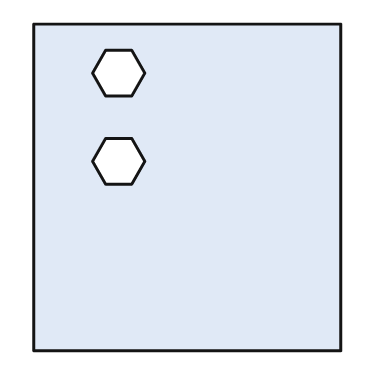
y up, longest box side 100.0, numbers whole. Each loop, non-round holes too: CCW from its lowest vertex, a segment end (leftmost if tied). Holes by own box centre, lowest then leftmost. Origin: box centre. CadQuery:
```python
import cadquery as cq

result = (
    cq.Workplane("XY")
    .moveTo(-47.0, -50.0)
    .lineTo(47.0, -50.0)
    .lineTo(47.0, 50.0)
    .lineTo(-47.0, 50.0)
    .close()
    .moveTo(-25.0, 1.0)
    .lineTo(-17.0, 1.0)
    .lineTo(-13.0, 8.0)
    .lineTo(-17.0, 15.0)
    .lineTo(-25.0, 15.0)
    .lineTo(-29.0, 8.0)
    .close()
    .moveTo(-25.0, 28.0)
    .lineTo(-17.0, 28.0)
    .lineTo(-13.0, 35.0)
    .lineTo(-17.0, 42.0)
    .lineTo(-25.0, 42.0)
    .lineTo(-29.0, 35.0)
    .close()
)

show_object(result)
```